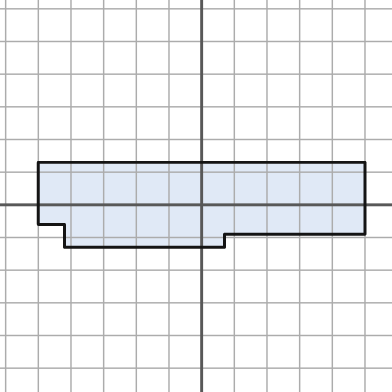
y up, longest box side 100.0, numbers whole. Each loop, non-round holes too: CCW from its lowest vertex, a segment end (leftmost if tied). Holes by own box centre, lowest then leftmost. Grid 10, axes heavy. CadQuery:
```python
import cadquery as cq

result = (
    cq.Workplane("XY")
    .moveTo(-42.0, -13.0)
    .lineTo(7.0, -13.0)
    .lineTo(7.0, -9.0)
    .lineTo(50.0, -9.0)
    .lineTo(50.0, 13.0)
    .lineTo(-50.0, 13.0)
    .lineTo(-50.0, -6.0)
    .lineTo(-42.0, -6.0)
    .close()
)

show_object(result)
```